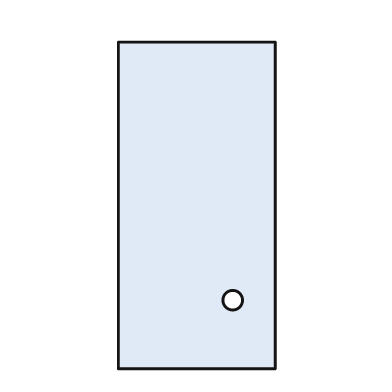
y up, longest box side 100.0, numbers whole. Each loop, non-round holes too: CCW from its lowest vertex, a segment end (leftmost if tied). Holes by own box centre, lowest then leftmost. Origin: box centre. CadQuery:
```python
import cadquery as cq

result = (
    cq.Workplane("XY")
    .moveTo(-24.0, -50.0)
    .lineTo(24.0, -50.0)
    .lineTo(24.0, 50.0)
    .lineTo(-24.0, 50.0)
    .close()
    .moveTo(11.0, -29.0)
    .circle(3.0)
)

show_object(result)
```